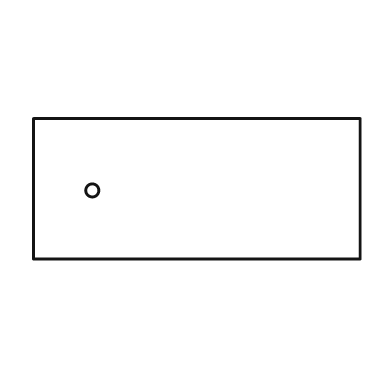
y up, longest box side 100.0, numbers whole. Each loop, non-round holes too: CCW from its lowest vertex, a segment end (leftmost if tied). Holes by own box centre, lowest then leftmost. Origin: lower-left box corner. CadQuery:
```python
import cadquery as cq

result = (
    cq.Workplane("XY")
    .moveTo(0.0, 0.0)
    .lineTo(100.0, 0.0)
    .lineTo(100.0, 43.0)
    .lineTo(0.0, 43.0)
    .close()
    .moveTo(18.0, 21.0)
    .circle(2.0)
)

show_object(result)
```